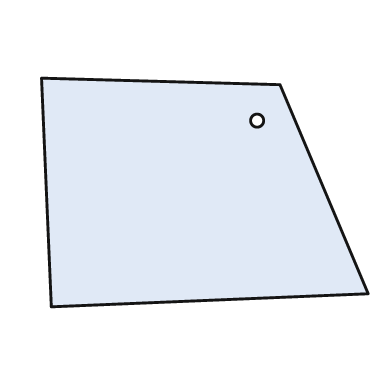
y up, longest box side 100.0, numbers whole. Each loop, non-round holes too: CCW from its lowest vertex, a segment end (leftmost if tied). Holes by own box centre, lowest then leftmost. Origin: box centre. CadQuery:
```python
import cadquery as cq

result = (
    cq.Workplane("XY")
    .moveTo(-47.0, -35.0)
    .lineTo(50.0, -31.0)
    .lineTo(23.0, 33.0)
    .lineTo(-50.0, 35.0)
    .close()
    .moveTo(16.0, 22.0)
    .circle(2.0)
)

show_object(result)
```